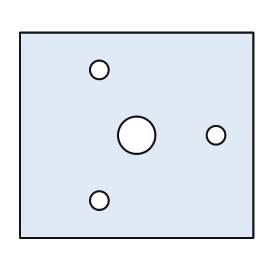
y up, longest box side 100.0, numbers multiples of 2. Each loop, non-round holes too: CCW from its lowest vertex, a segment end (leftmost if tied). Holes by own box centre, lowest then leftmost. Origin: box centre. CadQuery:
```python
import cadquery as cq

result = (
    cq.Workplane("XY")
    .moveTo(-50.0, -44.0)
    .lineTo(50.0, -44.0)
    .lineTo(50.0, 44.0)
    .lineTo(-50.0, 44.0)
    .close()
    .moveTo(-16.0, -28.0)
    .circle(4.0)
    .moveTo(0.0, 0.0)
    .circle(8.0)
    .moveTo(34.0, 0.0)
    .circle(4.0)
    .moveTo(-16.0, 28.0)
    .circle(4.0)
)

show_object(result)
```